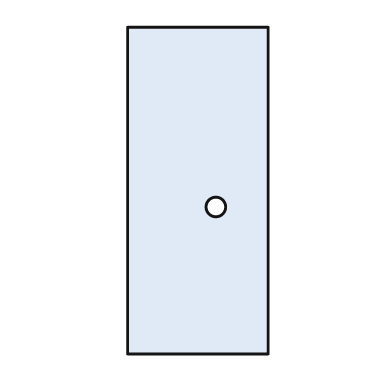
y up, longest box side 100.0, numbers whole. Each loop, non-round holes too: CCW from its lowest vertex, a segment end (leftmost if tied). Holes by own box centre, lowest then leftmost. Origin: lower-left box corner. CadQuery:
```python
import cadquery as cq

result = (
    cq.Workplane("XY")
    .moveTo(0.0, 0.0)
    .lineTo(43.0, 0.0)
    .lineTo(43.0, 100.0)
    .lineTo(0.0, 100.0)
    .close()
    .moveTo(27.0, 45.0)
    .circle(3.0)
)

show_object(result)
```